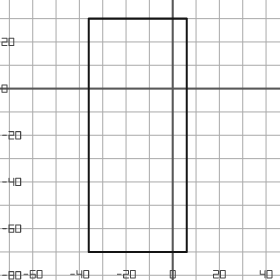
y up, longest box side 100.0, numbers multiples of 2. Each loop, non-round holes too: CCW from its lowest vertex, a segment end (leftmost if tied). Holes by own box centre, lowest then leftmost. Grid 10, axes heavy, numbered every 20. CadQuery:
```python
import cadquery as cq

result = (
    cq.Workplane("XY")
    .moveTo(-36.0, -70.0)
    .lineTo(6.0, -70.0)
    .lineTo(6.0, 30.0)
    .lineTo(-36.0, 30.0)
    .close()
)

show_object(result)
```